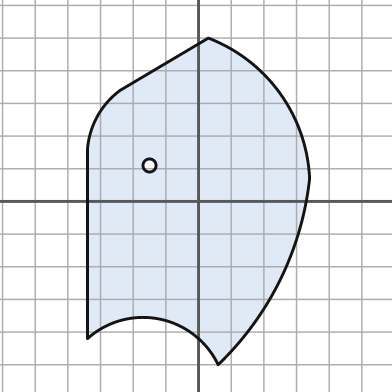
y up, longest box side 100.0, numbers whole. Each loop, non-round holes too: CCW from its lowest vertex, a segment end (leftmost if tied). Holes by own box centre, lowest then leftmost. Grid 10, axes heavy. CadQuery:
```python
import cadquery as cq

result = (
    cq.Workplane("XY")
    .moveTo(6.0, -50.0)
    .threePointArc((25.0, -24.0), (34.0, 7.0))
    .threePointArc((25.0, 33.0), (3.0, 50.0))
    .lineTo(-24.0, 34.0)
    .threePointArc((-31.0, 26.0), (-34.0, 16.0))
    .lineTo(-34.0, -42.0)
    .threePointArc((-12.0, -36.0), (6.0, -50.0))
    .close()
    .moveTo(-15.0, 11.0)
    .circle(2.0)
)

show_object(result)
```